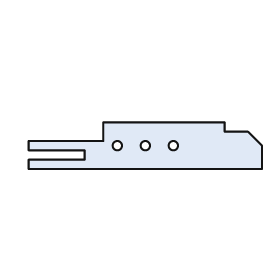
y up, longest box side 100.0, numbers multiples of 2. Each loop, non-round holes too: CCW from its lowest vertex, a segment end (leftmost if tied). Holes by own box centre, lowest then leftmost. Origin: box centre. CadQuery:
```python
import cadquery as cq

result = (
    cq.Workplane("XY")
    .moveTo(-50.0, -10.0)
    .lineTo(50.0, -10.0)
    .lineTo(50.0, 0.0)
    .lineTo(44.0, 6.0)
    .lineTo(34.0, 6.0)
    .lineTo(34.0, 10.0)
    .lineTo(-18.0, 10.0)
    .lineTo(-18.0, 2.0)
    .lineTo(-50.0, 2.0)
    .lineTo(-50.0, -2.0)
    .lineTo(-26.0, -2.0)
    .lineTo(-26.0, -6.0)
    .lineTo(-50.0, -6.0)
    .close()
    .moveTo(-12.0, 0.0)
    .circle(2.0)
    .moveTo(0.0, 0.0)
    .circle(2.0)
    .moveTo(12.0, 0.0)
    .circle(2.0)
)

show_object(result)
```